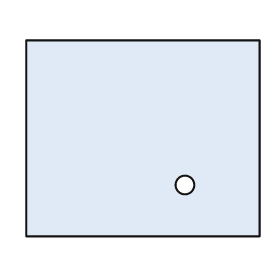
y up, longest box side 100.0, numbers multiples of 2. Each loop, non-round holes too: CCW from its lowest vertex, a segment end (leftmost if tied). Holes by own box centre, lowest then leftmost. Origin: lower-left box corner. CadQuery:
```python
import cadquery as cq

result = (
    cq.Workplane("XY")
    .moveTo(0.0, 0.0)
    .lineTo(100.0, 0.0)
    .lineTo(100.0, 84.0)
    .lineTo(0.0, 84.0)
    .close()
    .moveTo(68.0, 22.0)
    .circle(4.0)
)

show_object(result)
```